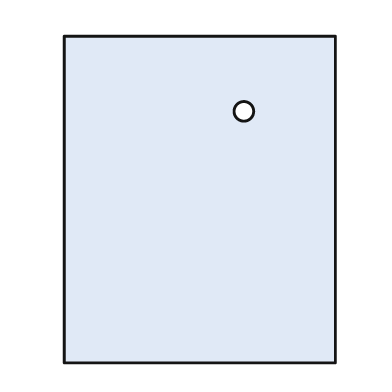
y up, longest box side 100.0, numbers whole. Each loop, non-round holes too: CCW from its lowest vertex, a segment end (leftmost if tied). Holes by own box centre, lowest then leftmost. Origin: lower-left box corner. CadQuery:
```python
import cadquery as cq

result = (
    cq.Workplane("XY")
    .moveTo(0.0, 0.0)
    .lineTo(83.0, 0.0)
    .lineTo(83.0, 100.0)
    .lineTo(0.0, 100.0)
    .close()
    .moveTo(55.0, 77.0)
    .circle(3.0)
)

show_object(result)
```